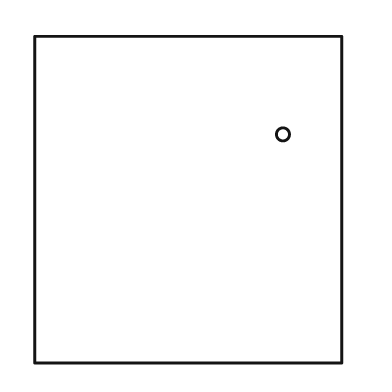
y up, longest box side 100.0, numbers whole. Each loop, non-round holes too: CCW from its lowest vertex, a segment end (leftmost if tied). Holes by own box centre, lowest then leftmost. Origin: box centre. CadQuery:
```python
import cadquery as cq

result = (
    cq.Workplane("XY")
    .moveTo(-47.0, -50.0)
    .lineTo(47.0, -50.0)
    .lineTo(47.0, 50.0)
    .lineTo(-47.0, 50.0)
    .close()
    .moveTo(29.0, 20.0)
    .circle(2.0)
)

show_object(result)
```